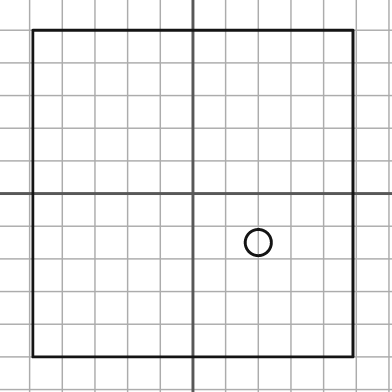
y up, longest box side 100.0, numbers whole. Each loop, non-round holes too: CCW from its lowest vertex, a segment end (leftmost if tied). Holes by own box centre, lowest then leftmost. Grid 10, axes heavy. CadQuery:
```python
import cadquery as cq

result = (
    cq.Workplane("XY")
    .moveTo(-49.0, -50.0)
    .lineTo(49.0, -50.0)
    .lineTo(49.0, 50.0)
    .lineTo(-49.0, 50.0)
    .close()
    .moveTo(20.0, -15.0)
    .circle(4.0)
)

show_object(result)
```